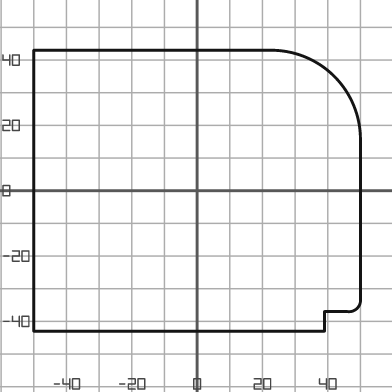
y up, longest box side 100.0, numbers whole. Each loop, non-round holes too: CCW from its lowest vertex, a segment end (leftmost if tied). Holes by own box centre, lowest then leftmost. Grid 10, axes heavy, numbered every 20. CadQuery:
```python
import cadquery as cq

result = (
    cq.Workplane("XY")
    .moveTo(-50.0, -43.0)
    .lineTo(39.0, -43.0)
    .lineTo(39.0, -37.0)
    .lineTo(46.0, -37.0)
    .threePointArc((49.0, -36.0), (50.0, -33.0))
    .lineTo(50.0, 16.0)
    .threePointArc((42.0, 35.0), (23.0, 43.0))
    .lineTo(-50.0, 43.0)
    .close()
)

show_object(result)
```